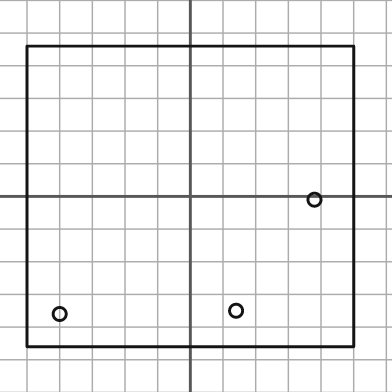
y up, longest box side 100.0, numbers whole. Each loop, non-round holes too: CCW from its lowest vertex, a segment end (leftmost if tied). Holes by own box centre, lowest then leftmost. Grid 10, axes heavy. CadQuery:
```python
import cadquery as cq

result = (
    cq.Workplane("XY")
    .moveTo(-50.0, -46.0)
    .lineTo(50.0, -46.0)
    .lineTo(50.0, 46.0)
    .lineTo(-50.0, 46.0)
    .close()
    .moveTo(-40.0, -36.0)
    .circle(2.0)
    .moveTo(14.0, -35.0)
    .circle(2.0)
    .moveTo(38.0, -1.0)
    .circle(2.0)
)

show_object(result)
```